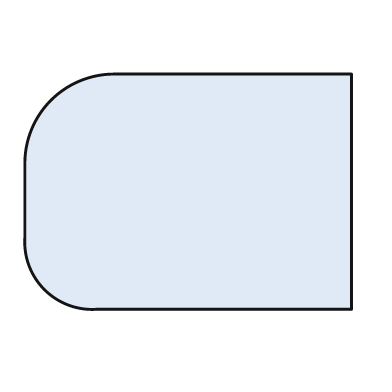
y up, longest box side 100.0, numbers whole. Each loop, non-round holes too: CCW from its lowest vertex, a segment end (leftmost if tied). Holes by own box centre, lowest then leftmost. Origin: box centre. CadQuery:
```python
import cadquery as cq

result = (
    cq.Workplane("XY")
    .moveTo(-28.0, -36.0)
    .lineTo(50.0, -36.0)
    .lineTo(50.0, 36.0)
    .lineTo(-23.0, 36.0)
    .threePointArc((-42.0, 28.0), (-50.0, 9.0))
    .lineTo(-50.0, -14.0)
    .threePointArc((-44.0, -30.0), (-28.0, -36.0))
    .close()
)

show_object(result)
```